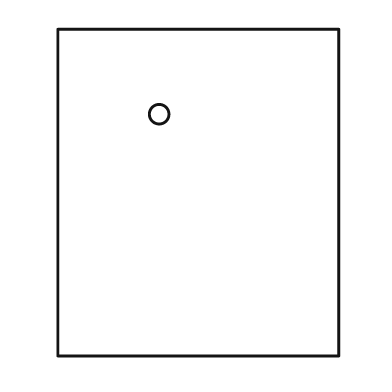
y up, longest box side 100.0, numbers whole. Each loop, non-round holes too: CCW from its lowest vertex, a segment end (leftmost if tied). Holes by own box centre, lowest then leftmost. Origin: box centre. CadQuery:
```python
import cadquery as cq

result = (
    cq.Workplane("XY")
    .moveTo(-43.0, -50.0)
    .lineTo(43.0, -50.0)
    .lineTo(43.0, 50.0)
    .lineTo(-43.0, 50.0)
    .close()
    .moveTo(-12.0, 24.0)
    .circle(3.0)
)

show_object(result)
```